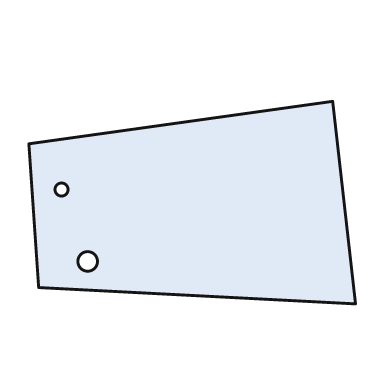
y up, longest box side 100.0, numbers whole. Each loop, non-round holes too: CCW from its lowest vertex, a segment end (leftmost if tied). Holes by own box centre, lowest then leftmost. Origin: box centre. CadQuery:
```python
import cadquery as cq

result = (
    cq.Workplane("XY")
    .moveTo(50.0, -31.0)
    .lineTo(43.0, 31.0)
    .lineTo(-50.0, 18.0)
    .lineTo(-47.0, -26.0)
    .close()
    .moveTo(-32.0, -18.0)
    .circle(3.0)
    .moveTo(-40.0, 4.0)
    .circle(2.0)
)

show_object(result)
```